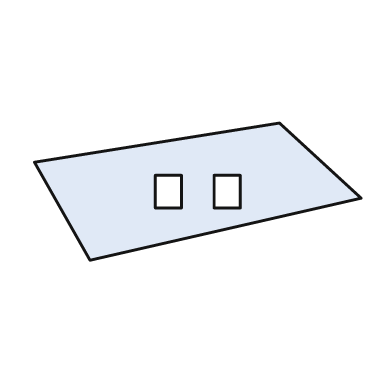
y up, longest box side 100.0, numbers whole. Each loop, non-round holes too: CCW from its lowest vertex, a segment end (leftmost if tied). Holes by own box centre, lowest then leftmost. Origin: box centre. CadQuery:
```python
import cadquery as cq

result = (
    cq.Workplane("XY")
    .moveTo(-33.0, -21.0)
    .lineTo(50.0, -2.0)
    .lineTo(25.0, 21.0)
    .lineTo(-50.0, 9.0)
    .close()
    .moveTo(-13.0, -5.0)
    .lineTo(-5.0, -5.0)
    .lineTo(-5.0, 5.0)
    .lineTo(-13.0, 5.0)
    .close()
    .moveTo(5.0, -5.0)
    .lineTo(13.0, -5.0)
    .lineTo(13.0, 5.0)
    .lineTo(5.0, 5.0)
    .close()
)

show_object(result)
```